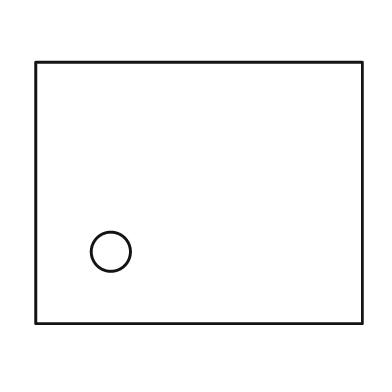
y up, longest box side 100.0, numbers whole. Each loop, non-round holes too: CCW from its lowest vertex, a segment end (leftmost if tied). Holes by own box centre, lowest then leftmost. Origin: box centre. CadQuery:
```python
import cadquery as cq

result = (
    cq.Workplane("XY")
    .moveTo(-50.0, -40.0)
    .lineTo(50.0, -40.0)
    .lineTo(50.0, 40.0)
    .lineTo(-50.0, 40.0)
    .close()
    .moveTo(-27.0, -18.0)
    .circle(6.0)
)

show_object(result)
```